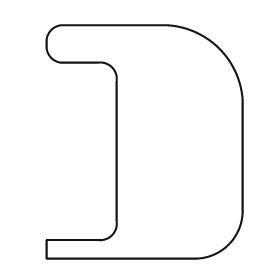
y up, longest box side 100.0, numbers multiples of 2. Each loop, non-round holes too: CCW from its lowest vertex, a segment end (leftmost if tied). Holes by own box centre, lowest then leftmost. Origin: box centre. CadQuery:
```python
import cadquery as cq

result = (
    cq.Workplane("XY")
    .moveTo(-42.0, -50.0)
    .lineTo(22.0, -50.0)
    .threePointArc((36.0, -44.0), (42.0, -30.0))
    .lineTo(42.0, 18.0)
    .threePointArc((32.0, 40.0), (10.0, 50.0))
    .lineTo(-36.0, 50.0)
    .threePointArc((-40.0, 48.0), (-42.0, 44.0))
    .lineTo(-42.0, 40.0)
    .threePointArc((-40.0, 36.0), (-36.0, 34.0))
    .lineTo(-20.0, 34.0)
    .threePointArc((-14.0, 32.0), (-12.0, 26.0))
    .lineTo(-12.0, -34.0)
    .threePointArc((-14.0, -40.0), (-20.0, -42.0))
    .lineTo(-42.0, -42.0)
    .close()
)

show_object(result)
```